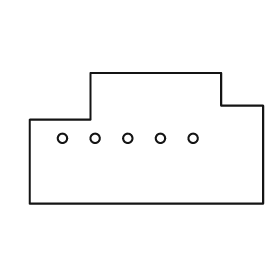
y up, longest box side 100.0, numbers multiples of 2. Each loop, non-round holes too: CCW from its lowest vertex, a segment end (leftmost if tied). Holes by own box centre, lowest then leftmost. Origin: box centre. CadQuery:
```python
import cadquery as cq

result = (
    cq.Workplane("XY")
    .moveTo(-50.0, -28.0)
    .lineTo(50.0, -28.0)
    .lineTo(50.0, 14.0)
    .lineTo(32.0, 14.0)
    .lineTo(32.0, 28.0)
    .lineTo(-24.0, 28.0)
    .lineTo(-24.0, 8.0)
    .lineTo(-50.0, 8.0)
    .close()
    .moveTo(-36.0, 0.0)
    .circle(2.0)
    .moveTo(-22.0, 0.0)
    .circle(2.0)
    .moveTo(-8.0, 0.0)
    .circle(2.0)
    .moveTo(6.0, 0.0)
    .circle(2.0)
    .moveTo(20.0, 0.0)
    .circle(2.0)
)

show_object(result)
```